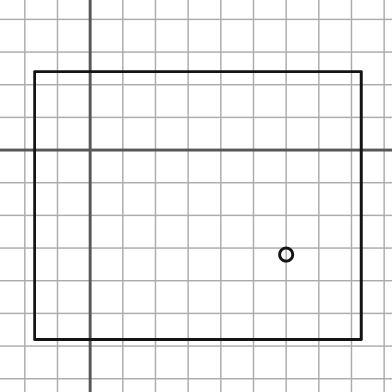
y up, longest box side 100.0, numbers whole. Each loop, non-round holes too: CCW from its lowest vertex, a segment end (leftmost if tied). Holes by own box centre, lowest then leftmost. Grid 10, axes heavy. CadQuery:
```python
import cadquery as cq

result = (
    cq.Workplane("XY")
    .moveTo(-17.0, -58.0)
    .lineTo(83.0, -58.0)
    .lineTo(83.0, 24.0)
    .lineTo(-17.0, 24.0)
    .close()
    .moveTo(60.0, -32.0)
    .circle(2.0)
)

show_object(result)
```